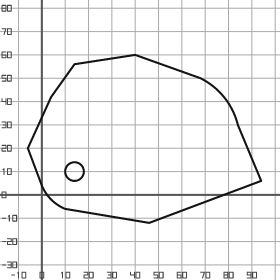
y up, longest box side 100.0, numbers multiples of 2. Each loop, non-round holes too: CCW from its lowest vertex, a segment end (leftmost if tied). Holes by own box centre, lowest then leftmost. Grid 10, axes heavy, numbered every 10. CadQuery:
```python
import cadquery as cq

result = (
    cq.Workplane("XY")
    .moveTo(46.0, -12.0)
    .lineTo(94.0, 6.0)
    .lineTo(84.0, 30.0)
    .threePointArc((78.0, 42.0), (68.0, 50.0))
    .lineTo(40.0, 60.0)
    .lineTo(14.0, 56.0)
    .lineTo(4.0, 42.0)
    .lineTo(-6.0, 20.0)
    .lineTo(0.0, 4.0)
    .threePointArc((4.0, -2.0), (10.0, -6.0))
    .close()
    .moveTo(14.0, 10.0)
    .circle(4.0)
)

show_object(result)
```